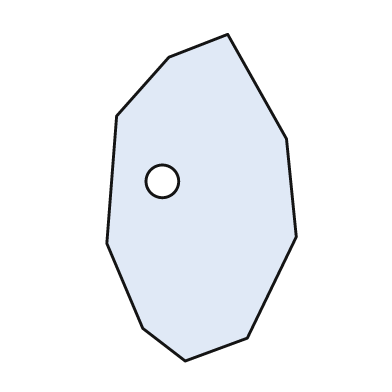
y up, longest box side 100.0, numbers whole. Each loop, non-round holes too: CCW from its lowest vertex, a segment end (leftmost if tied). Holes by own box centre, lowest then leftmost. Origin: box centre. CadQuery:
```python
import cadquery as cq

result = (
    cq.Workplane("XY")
    .moveTo(-5.0, -50.0)
    .lineTo(14.0, -43.0)
    .lineTo(29.0, -12.0)
    .lineTo(26.0, 18.0)
    .lineTo(8.0, 50.0)
    .lineTo(-10.0, 43.0)
    .lineTo(-26.0, 25.0)
    .lineTo(-29.0, -14.0)
    .lineTo(-18.0, -40.0)
    .close()
    .moveTo(-12.0, 5.0)
    .circle(5.0)
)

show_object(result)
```